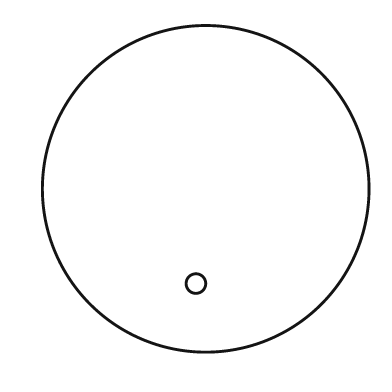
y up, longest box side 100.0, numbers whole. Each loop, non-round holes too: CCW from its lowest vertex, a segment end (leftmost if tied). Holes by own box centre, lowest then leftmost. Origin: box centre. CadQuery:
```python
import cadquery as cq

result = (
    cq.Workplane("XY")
    .moveTo(0.0, 0.0)
    .circle(50.0)
    .moveTo(-3.0, -29.0)
    .circle(3.0)
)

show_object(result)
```